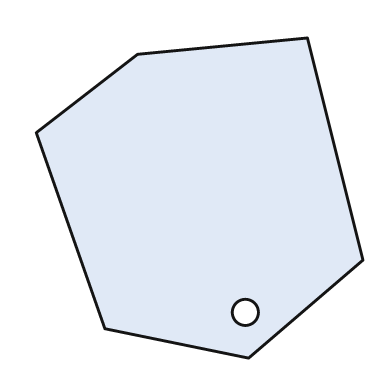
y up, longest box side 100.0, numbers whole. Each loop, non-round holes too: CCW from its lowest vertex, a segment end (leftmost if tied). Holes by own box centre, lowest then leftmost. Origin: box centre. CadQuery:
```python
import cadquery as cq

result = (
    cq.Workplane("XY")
    .moveTo(15.0, -49.0)
    .lineTo(50.0, -19.0)
    .lineTo(33.0, 49.0)
    .lineTo(-19.0, 44.0)
    .lineTo(-50.0, 20.0)
    .lineTo(-29.0, -40.0)
    .close()
    .moveTo(14.0, -35.0)
    .circle(4.0)
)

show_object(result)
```